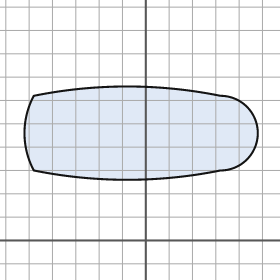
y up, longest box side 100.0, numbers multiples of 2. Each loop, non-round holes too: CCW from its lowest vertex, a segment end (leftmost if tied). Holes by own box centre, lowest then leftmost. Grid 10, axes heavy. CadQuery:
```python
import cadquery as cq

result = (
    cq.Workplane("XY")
    .moveTo(-48.0, 30.0)
    .threePointArc((-8.0, 26.0), (32.0, 30.0))
    .threePointArc((48.0, 46.0), (32.0, 62.0))
    .threePointArc((-8.0, 66.0), (-48.0, 62.0))
    .threePointArc((-52.0, 46.0), (-48.0, 30.0))
    .close()
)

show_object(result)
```